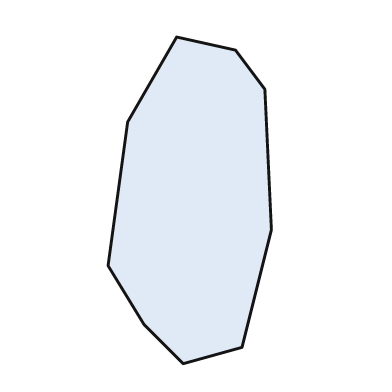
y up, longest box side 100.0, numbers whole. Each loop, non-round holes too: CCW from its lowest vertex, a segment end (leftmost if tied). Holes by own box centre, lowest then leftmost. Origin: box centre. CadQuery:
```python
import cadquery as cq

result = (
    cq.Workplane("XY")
    .moveTo(-2.0, -50.0)
    .lineTo(16.0, -45.0)
    .lineTo(25.0, -9.0)
    .lineTo(23.0, 34.0)
    .lineTo(14.0, 46.0)
    .lineTo(-4.0, 50.0)
    .lineTo(-19.0, 24.0)
    .lineTo(-25.0, -20.0)
    .lineTo(-14.0, -38.0)
    .close()
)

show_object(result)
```